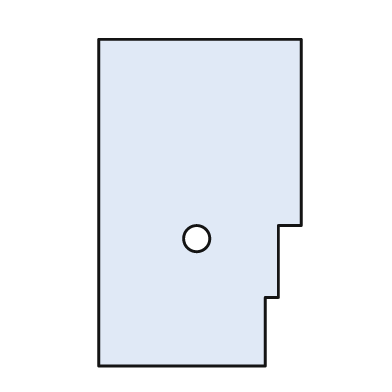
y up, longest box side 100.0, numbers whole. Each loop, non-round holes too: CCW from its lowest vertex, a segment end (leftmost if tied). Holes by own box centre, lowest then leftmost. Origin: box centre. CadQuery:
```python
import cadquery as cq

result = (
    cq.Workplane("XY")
    .moveTo(-31.0, -50.0)
    .lineTo(20.0, -50.0)
    .lineTo(20.0, -29.0)
    .lineTo(24.0, -29.0)
    .lineTo(24.0, -7.0)
    .lineTo(31.0, -7.0)
    .lineTo(31.0, 50.0)
    .lineTo(-31.0, 50.0)
    .close()
    .moveTo(-1.0, -11.0)
    .circle(4.0)
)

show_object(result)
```